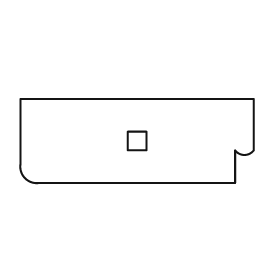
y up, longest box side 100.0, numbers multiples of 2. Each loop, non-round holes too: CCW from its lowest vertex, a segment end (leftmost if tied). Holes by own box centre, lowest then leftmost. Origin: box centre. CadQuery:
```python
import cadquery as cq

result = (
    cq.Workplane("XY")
    .moveTo(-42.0, -18.0)
    .lineTo(42.0, -18.0)
    .lineTo(42.0, -4.0)
    .threePointArc((46.0, -6.0), (50.0, -4.0))
    .lineTo(50.0, 18.0)
    .lineTo(-50.0, 18.0)
    .lineTo(-50.0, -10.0)
    .threePointArc((-48.0, -16.0), (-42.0, -18.0))
    .close()
    .moveTo(-4.0, -4.0)
    .lineTo(4.0, -4.0)
    .lineTo(4.0, 4.0)
    .lineTo(-4.0, 4.0)
    .close()
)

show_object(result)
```